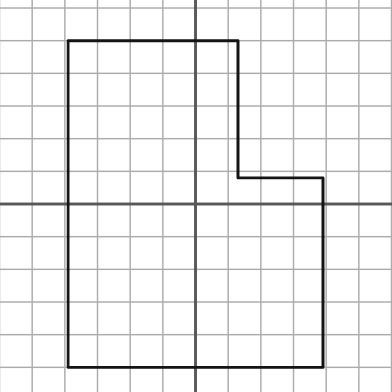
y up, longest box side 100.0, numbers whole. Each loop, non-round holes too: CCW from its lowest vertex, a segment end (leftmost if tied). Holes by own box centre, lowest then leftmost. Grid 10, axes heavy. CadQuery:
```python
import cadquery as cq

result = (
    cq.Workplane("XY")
    .moveTo(-39.0, -50.0)
    .lineTo(39.0, -50.0)
    .lineTo(39.0, 8.0)
    .lineTo(13.0, 8.0)
    .lineTo(13.0, 50.0)
    .lineTo(-39.0, 50.0)
    .close()
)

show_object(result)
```